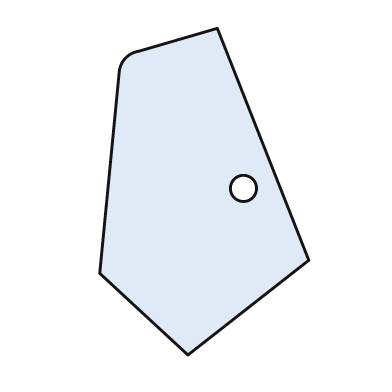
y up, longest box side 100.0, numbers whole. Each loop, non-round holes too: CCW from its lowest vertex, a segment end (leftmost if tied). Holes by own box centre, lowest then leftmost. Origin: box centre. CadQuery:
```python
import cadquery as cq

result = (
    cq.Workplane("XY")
    .moveTo(-5.0, -50.0)
    .lineTo(32.0, -21.0)
    .lineTo(4.0, 50.0)
    .lineTo(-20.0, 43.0)
    .threePointArc((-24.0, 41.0), (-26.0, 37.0))
    .lineTo(-32.0, -25.0)
    .close()
    .moveTo(12.0, 1.0)
    .circle(4.0)
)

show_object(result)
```